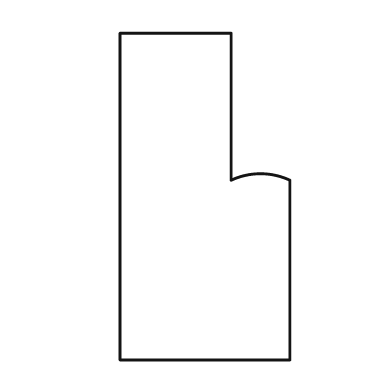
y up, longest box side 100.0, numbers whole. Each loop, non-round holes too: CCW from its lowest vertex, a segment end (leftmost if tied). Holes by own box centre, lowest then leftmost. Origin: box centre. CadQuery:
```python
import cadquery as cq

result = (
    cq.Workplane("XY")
    .moveTo(-26.0, -50.0)
    .lineTo(26.0, -50.0)
    .lineTo(26.0, 5.0)
    .threePointArc((17.0, 7.0), (8.0, 5.0))
    .lineTo(8.0, 50.0)
    .lineTo(-26.0, 50.0)
    .close()
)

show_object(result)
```